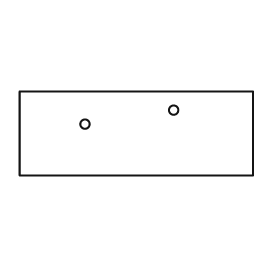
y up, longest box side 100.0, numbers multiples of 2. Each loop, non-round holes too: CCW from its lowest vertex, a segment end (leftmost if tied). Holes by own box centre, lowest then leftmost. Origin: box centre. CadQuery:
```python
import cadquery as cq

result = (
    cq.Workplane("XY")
    .moveTo(-50.0, -18.0)
    .lineTo(50.0, -18.0)
    .lineTo(50.0, 18.0)
    .lineTo(-50.0, 18.0)
    .close()
    .moveTo(-22.0, 4.0)
    .circle(2.0)
    .moveTo(16.0, 10.0)
    .circle(2.0)
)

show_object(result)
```